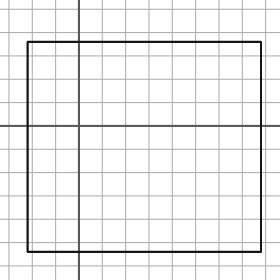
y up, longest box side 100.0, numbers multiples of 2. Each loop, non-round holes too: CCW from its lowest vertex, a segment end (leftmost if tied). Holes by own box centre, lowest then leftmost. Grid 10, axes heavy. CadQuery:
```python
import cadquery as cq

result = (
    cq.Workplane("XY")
    .moveTo(-22.0, -54.0)
    .lineTo(78.0, -54.0)
    .lineTo(78.0, 36.0)
    .lineTo(-22.0, 36.0)
    .close()
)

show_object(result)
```